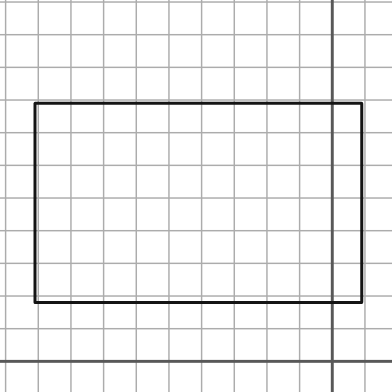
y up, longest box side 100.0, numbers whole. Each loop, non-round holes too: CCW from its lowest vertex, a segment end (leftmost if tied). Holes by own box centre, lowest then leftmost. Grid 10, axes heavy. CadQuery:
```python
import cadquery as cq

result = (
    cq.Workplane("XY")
    .moveTo(-91.0, 18.0)
    .lineTo(9.0, 18.0)
    .lineTo(9.0, 79.0)
    .lineTo(-91.0, 79.0)
    .close()
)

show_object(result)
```